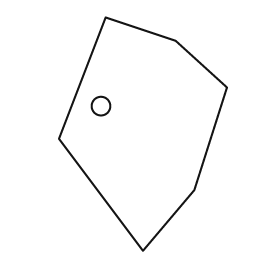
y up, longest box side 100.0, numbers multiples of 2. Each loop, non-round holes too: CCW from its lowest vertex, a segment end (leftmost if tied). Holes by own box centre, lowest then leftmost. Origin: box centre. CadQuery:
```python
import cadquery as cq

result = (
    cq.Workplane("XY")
    .moveTo(0.0, -50.0)
    .lineTo(22.0, -24.0)
    .lineTo(36.0, 20.0)
    .lineTo(14.0, 40.0)
    .lineTo(-16.0, 50.0)
    .lineTo(-36.0, -2.0)
    .close()
    .moveTo(-18.0, 12.0)
    .circle(4.0)
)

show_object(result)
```